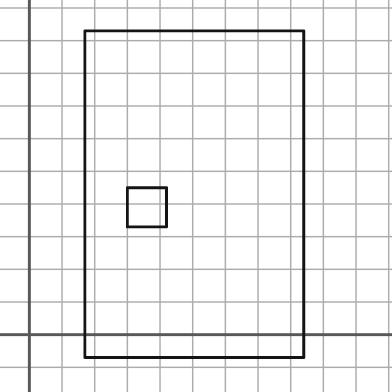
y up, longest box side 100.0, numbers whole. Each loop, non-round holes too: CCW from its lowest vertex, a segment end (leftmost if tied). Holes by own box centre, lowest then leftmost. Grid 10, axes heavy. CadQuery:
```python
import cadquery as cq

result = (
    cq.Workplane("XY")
    .moveTo(17.0, -7.0)
    .lineTo(84.0, -7.0)
    .lineTo(84.0, 93.0)
    .lineTo(17.0, 93.0)
    .close()
    .moveTo(30.0, 33.0)
    .lineTo(42.0, 33.0)
    .lineTo(42.0, 45.0)
    .lineTo(30.0, 45.0)
    .close()
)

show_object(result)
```